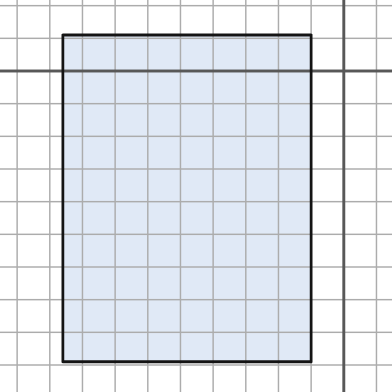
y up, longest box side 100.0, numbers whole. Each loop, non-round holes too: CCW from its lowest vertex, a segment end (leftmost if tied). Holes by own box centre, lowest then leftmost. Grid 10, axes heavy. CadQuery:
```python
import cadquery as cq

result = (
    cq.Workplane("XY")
    .moveTo(-86.0, -89.0)
    .lineTo(-10.0, -89.0)
    .lineTo(-10.0, 11.0)
    .lineTo(-86.0, 11.0)
    .close()
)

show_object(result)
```